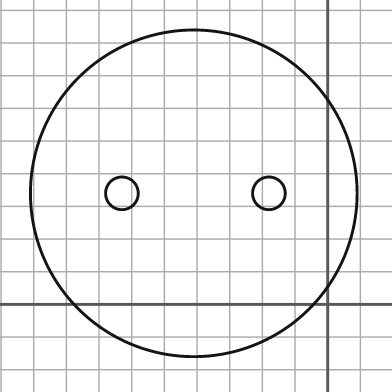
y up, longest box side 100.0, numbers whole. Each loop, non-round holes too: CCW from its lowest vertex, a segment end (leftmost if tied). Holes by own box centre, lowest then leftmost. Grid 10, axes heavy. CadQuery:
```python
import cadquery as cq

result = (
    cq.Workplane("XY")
    .moveTo(-41.0, 34.0)
    .circle(50.0)
    .moveTo(-63.0, 34.0)
    .circle(5.0)
    .moveTo(-18.0, 34.0)
    .circle(5.0)
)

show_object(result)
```